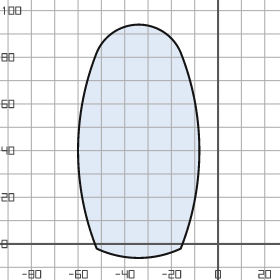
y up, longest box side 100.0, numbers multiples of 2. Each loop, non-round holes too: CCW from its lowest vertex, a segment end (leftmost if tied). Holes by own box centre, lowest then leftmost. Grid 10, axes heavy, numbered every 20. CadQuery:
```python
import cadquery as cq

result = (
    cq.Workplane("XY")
    .moveTo(-52.0, -2.0)
    .threePointArc((-34.0, -6.0), (-16.0, -2.0))
    .threePointArc((-8.0, 40.0), (-16.0, 82.0))
    .threePointArc((-34.0, 94.0), (-52.0, 82.0))
    .threePointArc((-60.0, 40.0), (-52.0, -2.0))
    .close()
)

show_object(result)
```